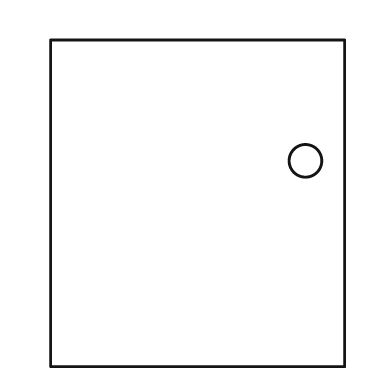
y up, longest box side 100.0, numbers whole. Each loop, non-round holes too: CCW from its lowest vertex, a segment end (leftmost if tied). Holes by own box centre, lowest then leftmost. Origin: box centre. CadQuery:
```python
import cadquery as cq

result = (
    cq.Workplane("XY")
    .moveTo(-45.0, -50.0)
    .lineTo(45.0, -50.0)
    .lineTo(45.0, 50.0)
    .lineTo(-45.0, 50.0)
    .close()
    .moveTo(33.0, 13.0)
    .circle(5.0)
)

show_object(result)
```